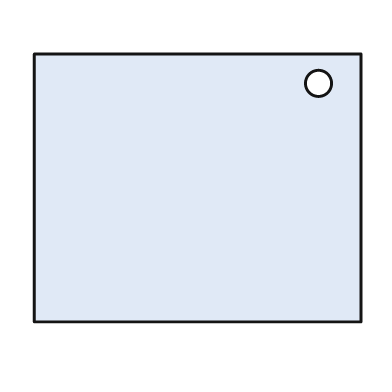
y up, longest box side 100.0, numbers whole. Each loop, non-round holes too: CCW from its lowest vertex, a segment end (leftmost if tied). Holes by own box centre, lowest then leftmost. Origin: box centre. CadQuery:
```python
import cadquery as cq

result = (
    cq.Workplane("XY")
    .moveTo(-50.0, -41.0)
    .lineTo(50.0, -41.0)
    .lineTo(50.0, 41.0)
    .lineTo(-50.0, 41.0)
    .close()
    .moveTo(37.0, 32.0)
    .circle(4.0)
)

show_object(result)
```